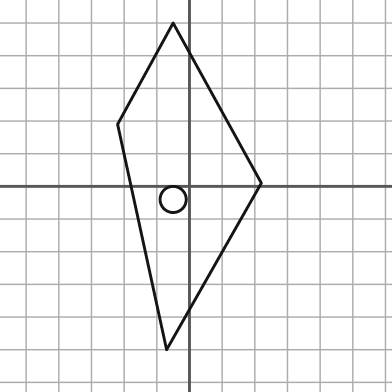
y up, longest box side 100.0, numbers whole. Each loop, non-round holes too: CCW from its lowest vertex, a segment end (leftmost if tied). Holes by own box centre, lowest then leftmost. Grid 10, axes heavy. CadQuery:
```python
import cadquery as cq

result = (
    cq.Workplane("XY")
    .moveTo(-7.0, -50.0)
    .lineTo(22.0, 1.0)
    .lineTo(-5.0, 50.0)
    .lineTo(-22.0, 19.0)
    .close()
    .moveTo(-5.0, -4.0)
    .circle(4.0)
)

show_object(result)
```